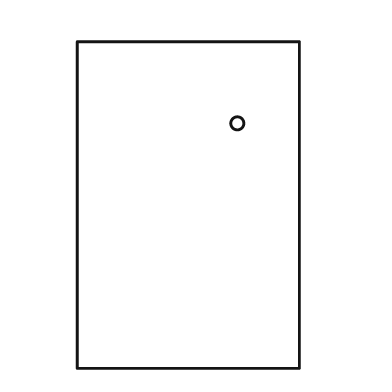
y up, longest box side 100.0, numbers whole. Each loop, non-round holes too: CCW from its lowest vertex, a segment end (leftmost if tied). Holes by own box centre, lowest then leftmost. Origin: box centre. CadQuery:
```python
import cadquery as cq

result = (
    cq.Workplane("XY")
    .moveTo(-34.0, -50.0)
    .lineTo(34.0, -50.0)
    .lineTo(34.0, 50.0)
    .lineTo(-34.0, 50.0)
    .close()
    .moveTo(15.0, 25.0)
    .circle(2.0)
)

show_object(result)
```